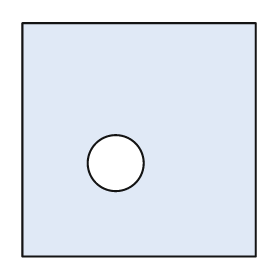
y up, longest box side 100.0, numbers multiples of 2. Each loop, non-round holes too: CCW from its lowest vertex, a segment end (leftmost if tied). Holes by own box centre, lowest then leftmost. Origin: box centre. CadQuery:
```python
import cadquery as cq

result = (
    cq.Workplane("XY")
    .moveTo(-50.0, -50.0)
    .lineTo(50.0, -50.0)
    .lineTo(50.0, 50.0)
    .lineTo(-50.0, 50.0)
    .close()
    .moveTo(-10.0, -10.0)
    .circle(12.0)
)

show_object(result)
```